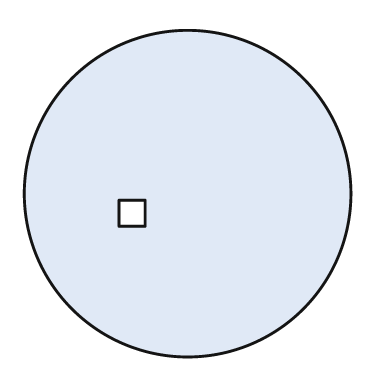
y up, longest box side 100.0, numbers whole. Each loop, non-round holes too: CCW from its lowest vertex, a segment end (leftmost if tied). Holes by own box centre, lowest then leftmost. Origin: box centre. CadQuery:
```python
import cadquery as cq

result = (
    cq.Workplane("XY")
    .moveTo(0.0, 0.0)
    .circle(50.0)
    .moveTo(-21.0, -10.0)
    .lineTo(-13.0, -10.0)
    .lineTo(-13.0, -2.0)
    .lineTo(-21.0, -2.0)
    .close()
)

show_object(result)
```